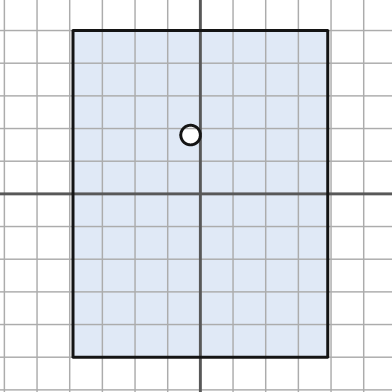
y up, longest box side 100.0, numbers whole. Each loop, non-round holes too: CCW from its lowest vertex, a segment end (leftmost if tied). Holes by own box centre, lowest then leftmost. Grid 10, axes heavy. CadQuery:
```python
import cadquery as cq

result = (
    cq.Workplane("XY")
    .moveTo(-39.0, -50.0)
    .lineTo(39.0, -50.0)
    .lineTo(39.0, 50.0)
    .lineTo(-39.0, 50.0)
    .close()
    .moveTo(-3.0, 18.0)
    .circle(3.0)
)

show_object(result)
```